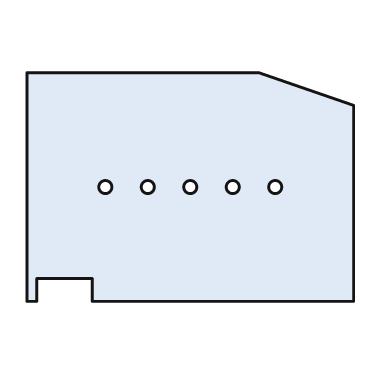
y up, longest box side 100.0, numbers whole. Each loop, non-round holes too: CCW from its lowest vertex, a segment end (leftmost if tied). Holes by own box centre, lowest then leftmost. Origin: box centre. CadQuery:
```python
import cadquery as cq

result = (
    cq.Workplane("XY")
    .moveTo(-50.0, -35.0)
    .lineTo(-47.0, -35.0)
    .lineTo(-47.0, -28.0)
    .lineTo(-30.0, -28.0)
    .lineTo(-30.0, -35.0)
    .lineTo(50.0, -35.0)
    .lineTo(50.0, 25.0)
    .lineTo(21.0, 35.0)
    .lineTo(-50.0, 35.0)
    .close()
    .moveTo(-26.0, 0.0)
    .circle(2.0)
    .moveTo(-13.0, 0.0)
    .circle(2.0)
    .moveTo(0.0, 0.0)
    .circle(2.0)
    .moveTo(13.0, 0.0)
    .circle(2.0)
    .moveTo(26.0, 0.0)
    .circle(2.0)
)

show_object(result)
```